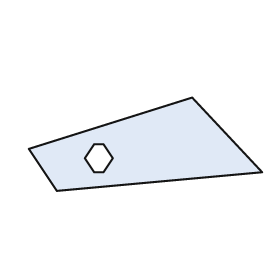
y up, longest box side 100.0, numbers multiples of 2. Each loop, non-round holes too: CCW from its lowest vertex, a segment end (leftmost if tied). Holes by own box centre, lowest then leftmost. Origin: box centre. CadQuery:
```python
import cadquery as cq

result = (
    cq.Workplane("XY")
    .moveTo(-38.0, -20.0)
    .lineTo(50.0, -12.0)
    .lineTo(20.0, 20.0)
    .lineTo(-50.0, -2.0)
    .close()
    .moveTo(-22.0, -12.0)
    .lineTo(-18.0, -12.0)
    .lineTo(-14.0, -6.0)
    .lineTo(-18.0, 0.0)
    .lineTo(-22.0, 0.0)
    .lineTo(-26.0, -6.0)
    .close()
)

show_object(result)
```